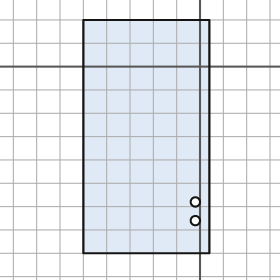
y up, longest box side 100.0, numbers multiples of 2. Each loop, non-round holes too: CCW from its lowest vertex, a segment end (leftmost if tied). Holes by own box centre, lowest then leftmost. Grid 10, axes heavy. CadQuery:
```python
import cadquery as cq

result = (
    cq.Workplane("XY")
    .moveTo(-50.0, -80.0)
    .lineTo(4.0, -80.0)
    .lineTo(4.0, 20.0)
    .lineTo(-50.0, 20.0)
    .close()
    .moveTo(-2.0, -66.0)
    .circle(2.0)
    .moveTo(-2.0, -58.0)
    .circle(2.0)
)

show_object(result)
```